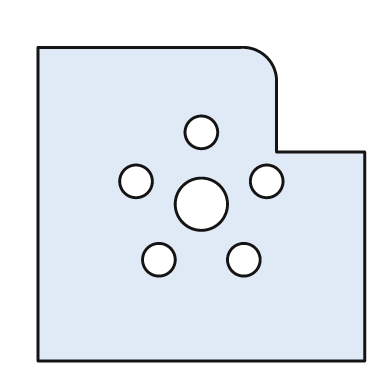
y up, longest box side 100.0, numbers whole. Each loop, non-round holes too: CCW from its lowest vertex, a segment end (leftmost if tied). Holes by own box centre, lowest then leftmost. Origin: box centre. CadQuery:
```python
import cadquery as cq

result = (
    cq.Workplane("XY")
    .moveTo(-50.0, -48.0)
    .lineTo(50.0, -48.0)
    .lineTo(50.0, 16.0)
    .lineTo(23.0, 16.0)
    .lineTo(23.0, 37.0)
    .threePointArc((20.0, 45.0), (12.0, 48.0))
    .lineTo(-50.0, 48.0)
    .close()
    .moveTo(-13.0, -17.0)
    .circle(5.0)
    .moveTo(13.0, -17.0)
    .circle(5.0)
    .moveTo(0.0, 0.0)
    .circle(8.0)
    .moveTo(-20.0, 7.0)
    .circle(5.0)
    .moveTo(20.0, 7.0)
    .circle(5.0)
    .moveTo(0.0, 22.0)
    .circle(5.0)
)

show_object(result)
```